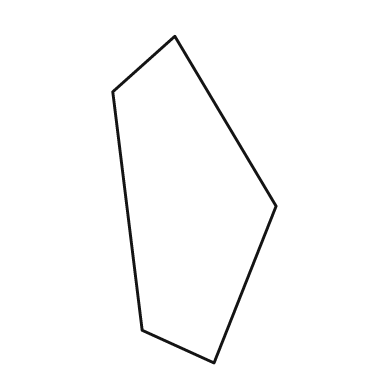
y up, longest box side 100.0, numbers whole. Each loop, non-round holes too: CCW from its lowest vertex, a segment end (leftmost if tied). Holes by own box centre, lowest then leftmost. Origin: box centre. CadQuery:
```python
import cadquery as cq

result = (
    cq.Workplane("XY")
    .moveTo(6.0, -50.0)
    .lineTo(25.0, -2.0)
    .lineTo(-6.0, 50.0)
    .lineTo(-25.0, 33.0)
    .lineTo(-16.0, -40.0)
    .close()
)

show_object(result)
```